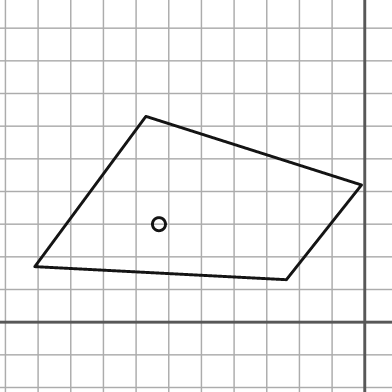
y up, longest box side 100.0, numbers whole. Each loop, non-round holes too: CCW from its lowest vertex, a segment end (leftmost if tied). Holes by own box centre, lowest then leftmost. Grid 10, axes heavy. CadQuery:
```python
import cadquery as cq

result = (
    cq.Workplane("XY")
    .moveTo(-24.0, 13.0)
    .lineTo(-1.0, 42.0)
    .lineTo(-67.0, 63.0)
    .lineTo(-101.0, 17.0)
    .close()
    .moveTo(-63.0, 30.0)
    .circle(2.0)
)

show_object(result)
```